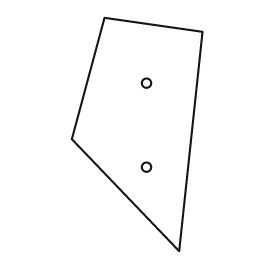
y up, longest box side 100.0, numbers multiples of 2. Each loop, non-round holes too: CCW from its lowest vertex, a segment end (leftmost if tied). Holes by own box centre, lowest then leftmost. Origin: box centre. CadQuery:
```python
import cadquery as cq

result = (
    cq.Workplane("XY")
    .moveTo(18.0, -50.0)
    .lineTo(28.0, 44.0)
    .lineTo(-14.0, 50.0)
    .lineTo(-28.0, -2.0)
    .close()
    .moveTo(4.0, -14.0)
    .circle(2.0)
    .moveTo(4.0, 22.0)
    .circle(2.0)
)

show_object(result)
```